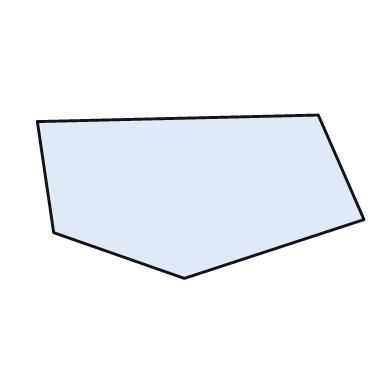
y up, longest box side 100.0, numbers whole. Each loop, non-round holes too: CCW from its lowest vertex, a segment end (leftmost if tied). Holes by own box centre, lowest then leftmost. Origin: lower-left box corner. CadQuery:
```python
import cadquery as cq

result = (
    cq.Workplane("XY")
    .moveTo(45.0, 0.0)
    .lineTo(100.0, 18.0)
    .lineTo(86.0, 50.0)
    .lineTo(0.0, 48.0)
    .lineTo(5.0, 14.0)
    .close()
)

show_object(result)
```